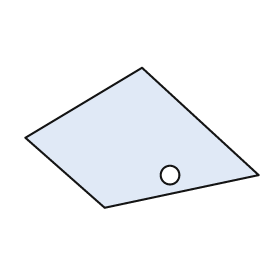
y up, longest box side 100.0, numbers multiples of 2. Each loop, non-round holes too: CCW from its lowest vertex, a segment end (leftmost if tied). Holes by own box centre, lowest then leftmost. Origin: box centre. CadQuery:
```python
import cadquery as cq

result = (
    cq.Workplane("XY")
    .moveTo(-16.0, -30.0)
    .lineTo(50.0, -16.0)
    .lineTo(0.0, 30.0)
    .lineTo(-50.0, 0.0)
    .close()
    .moveTo(12.0, -16.0)
    .circle(4.0)
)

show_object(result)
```